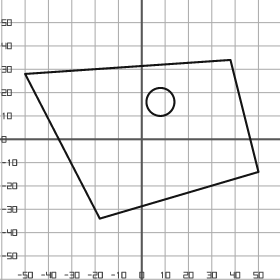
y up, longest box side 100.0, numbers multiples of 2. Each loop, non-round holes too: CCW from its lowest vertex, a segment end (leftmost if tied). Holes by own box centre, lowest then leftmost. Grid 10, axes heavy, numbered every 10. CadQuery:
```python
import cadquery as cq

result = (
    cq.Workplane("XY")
    .moveTo(-18.0, -34.0)
    .lineTo(50.0, -14.0)
    .lineTo(38.0, 34.0)
    .lineTo(-50.0, 28.0)
    .close()
    .moveTo(8.0, 16.0)
    .circle(6.0)
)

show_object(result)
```